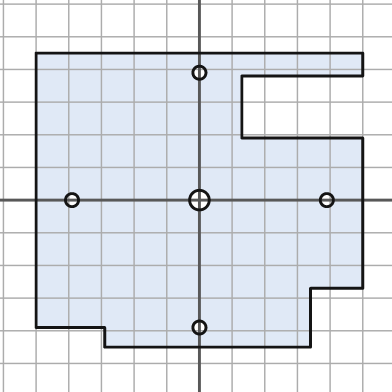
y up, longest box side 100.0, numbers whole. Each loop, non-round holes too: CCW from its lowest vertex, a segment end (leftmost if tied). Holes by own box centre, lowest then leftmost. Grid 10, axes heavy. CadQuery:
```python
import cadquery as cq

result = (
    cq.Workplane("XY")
    .moveTo(-29.0, -45.0)
    .lineTo(34.0, -45.0)
    .lineTo(34.0, -27.0)
    .lineTo(50.0, -27.0)
    .lineTo(50.0, 19.0)
    .lineTo(13.0, 19.0)
    .lineTo(13.0, 38.0)
    .lineTo(50.0, 38.0)
    .lineTo(50.0, 45.0)
    .lineTo(-50.0, 45.0)
    .lineTo(-50.0, -39.0)
    .lineTo(-29.0, -39.0)
    .close()
    .moveTo(0.0, -39.0)
    .circle(2.0)
    .moveTo(-39.0, 0.0)
    .circle(2.0)
    .moveTo(0.0, 0.0)
    .circle(3.0)
    .moveTo(39.0, 0.0)
    .circle(2.0)
    .moveTo(0.0, 39.0)
    .circle(2.0)
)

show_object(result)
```